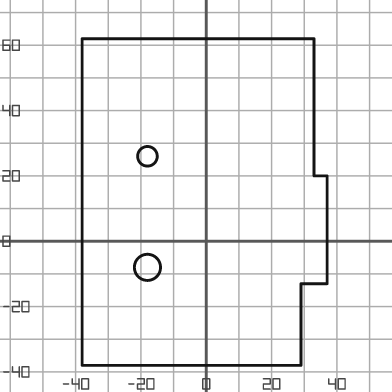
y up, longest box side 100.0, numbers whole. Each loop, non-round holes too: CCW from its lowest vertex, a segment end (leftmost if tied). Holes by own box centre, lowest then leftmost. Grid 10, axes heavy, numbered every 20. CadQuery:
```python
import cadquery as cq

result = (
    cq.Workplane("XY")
    .moveTo(-38.0, -38.0)
    .lineTo(29.0, -38.0)
    .lineTo(29.0, -13.0)
    .lineTo(37.0, -13.0)
    .lineTo(37.0, 20.0)
    .lineTo(33.0, 20.0)
    .lineTo(33.0, 62.0)
    .lineTo(-38.0, 62.0)
    .close()
    .moveTo(-18.0, -8.0)
    .circle(4.0)
    .moveTo(-18.0, 26.0)
    .circle(3.0)
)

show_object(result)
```